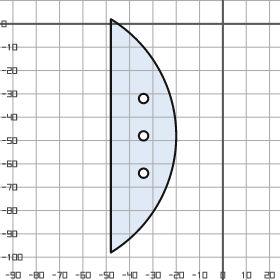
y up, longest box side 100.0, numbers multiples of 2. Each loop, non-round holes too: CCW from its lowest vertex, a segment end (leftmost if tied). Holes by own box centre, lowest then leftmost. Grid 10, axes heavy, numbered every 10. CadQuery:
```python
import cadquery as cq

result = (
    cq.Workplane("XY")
    .moveTo(-48.0, -98.0)
    .threePointArc((-20.0, -48.0), (-48.0, 2.0))
    .close()
    .moveTo(-34.0, -64.0)
    .circle(2.0)
    .moveTo(-34.0, -48.0)
    .circle(2.0)
    .moveTo(-34.0, -32.0)
    .circle(2.0)
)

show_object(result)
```